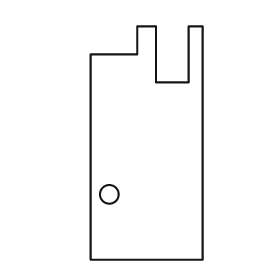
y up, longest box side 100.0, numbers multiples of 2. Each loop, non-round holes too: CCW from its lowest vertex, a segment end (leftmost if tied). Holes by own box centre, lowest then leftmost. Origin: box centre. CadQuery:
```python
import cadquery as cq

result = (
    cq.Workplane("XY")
    .moveTo(-24.0, -50.0)
    .lineTo(24.0, -50.0)
    .lineTo(24.0, 50.0)
    .lineTo(18.0, 50.0)
    .lineTo(18.0, 26.0)
    .lineTo(4.0, 26.0)
    .lineTo(4.0, 50.0)
    .lineTo(-4.0, 50.0)
    .lineTo(-4.0, 38.0)
    .lineTo(-24.0, 38.0)
    .close()
    .moveTo(-16.0, -22.0)
    .circle(4.0)
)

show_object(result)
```